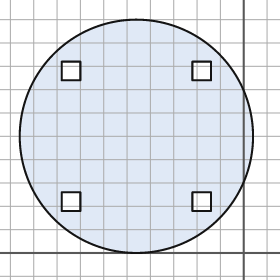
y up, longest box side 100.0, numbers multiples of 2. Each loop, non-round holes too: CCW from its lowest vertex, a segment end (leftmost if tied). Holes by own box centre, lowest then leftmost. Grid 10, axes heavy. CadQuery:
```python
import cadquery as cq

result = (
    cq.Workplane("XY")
    .moveTo(-46.0, 50.0)
    .circle(50.0)
    .moveTo(-78.0, 18.0)
    .lineTo(-70.0, 18.0)
    .lineTo(-70.0, 26.0)
    .lineTo(-78.0, 26.0)
    .close()
    .moveTo(-22.0, 18.0)
    .lineTo(-14.0, 18.0)
    .lineTo(-14.0, 26.0)
    .lineTo(-22.0, 26.0)
    .close()
    .moveTo(-78.0, 74.0)
    .lineTo(-70.0, 74.0)
    .lineTo(-70.0, 82.0)
    .lineTo(-78.0, 82.0)
    .close()
    .moveTo(-22.0, 74.0)
    .lineTo(-14.0, 74.0)
    .lineTo(-14.0, 82.0)
    .lineTo(-22.0, 82.0)
    .close()
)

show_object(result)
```